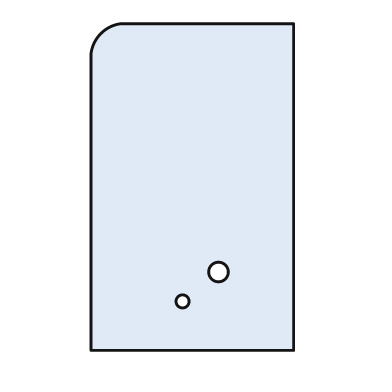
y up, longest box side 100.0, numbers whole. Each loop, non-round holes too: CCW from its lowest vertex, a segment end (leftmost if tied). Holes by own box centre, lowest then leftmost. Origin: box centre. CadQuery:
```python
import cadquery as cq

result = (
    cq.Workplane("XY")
    .moveTo(-31.0, -50.0)
    .lineTo(31.0, -50.0)
    .lineTo(31.0, 50.0)
    .lineTo(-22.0, 50.0)
    .threePointArc((-28.0, 47.0), (-31.0, 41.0))
    .close()
    .moveTo(-3.0, -35.0)
    .circle(2.0)
    .moveTo(8.0, -26.0)
    .circle(3.0)
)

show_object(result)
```